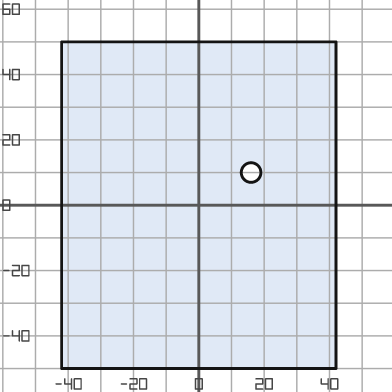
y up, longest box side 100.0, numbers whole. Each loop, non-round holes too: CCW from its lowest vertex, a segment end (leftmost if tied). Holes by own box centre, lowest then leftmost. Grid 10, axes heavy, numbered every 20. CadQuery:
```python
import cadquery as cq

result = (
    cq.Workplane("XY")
    .moveTo(-42.0, -50.0)
    .lineTo(42.0, -50.0)
    .lineTo(42.0, 50.0)
    .lineTo(-42.0, 50.0)
    .close()
    .moveTo(16.0, 10.0)
    .circle(3.0)
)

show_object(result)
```